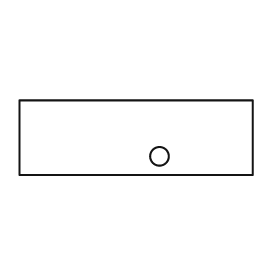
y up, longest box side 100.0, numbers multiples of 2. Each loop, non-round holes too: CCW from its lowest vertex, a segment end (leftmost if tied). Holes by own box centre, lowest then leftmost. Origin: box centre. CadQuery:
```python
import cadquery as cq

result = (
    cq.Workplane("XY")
    .moveTo(-50.0, -16.0)
    .lineTo(50.0, -16.0)
    .lineTo(50.0, 16.0)
    .lineTo(-50.0, 16.0)
    .close()
    .moveTo(10.0, -8.0)
    .circle(4.0)
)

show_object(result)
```